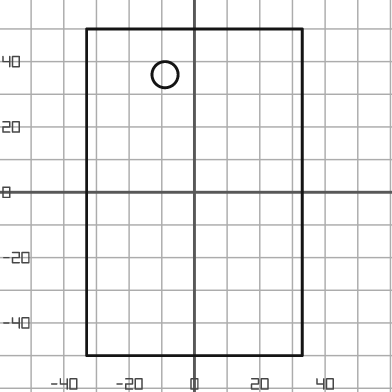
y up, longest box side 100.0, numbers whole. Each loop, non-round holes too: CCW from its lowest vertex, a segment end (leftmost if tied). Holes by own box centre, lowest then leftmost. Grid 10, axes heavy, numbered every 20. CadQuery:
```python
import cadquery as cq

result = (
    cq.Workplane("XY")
    .moveTo(-33.0, -50.0)
    .lineTo(33.0, -50.0)
    .lineTo(33.0, 50.0)
    .lineTo(-33.0, 50.0)
    .close()
    .moveTo(-9.0, 36.0)
    .circle(4.0)
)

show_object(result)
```